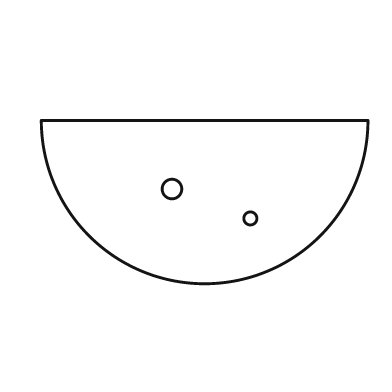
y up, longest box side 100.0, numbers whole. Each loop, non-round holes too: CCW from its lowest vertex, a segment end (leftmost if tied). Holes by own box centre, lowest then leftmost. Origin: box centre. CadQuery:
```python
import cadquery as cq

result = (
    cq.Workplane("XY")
    .moveTo(-50.0, 25.0)
    .threePointArc((0.0, -25.0), (50.0, 25.0))
    .close()
    .moveTo(14.0, -5.0)
    .circle(2.0)
    .moveTo(-10.0, 4.0)
    .circle(3.0)
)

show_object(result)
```